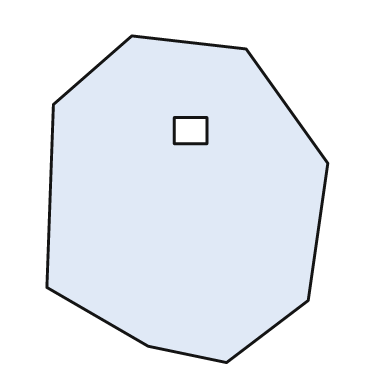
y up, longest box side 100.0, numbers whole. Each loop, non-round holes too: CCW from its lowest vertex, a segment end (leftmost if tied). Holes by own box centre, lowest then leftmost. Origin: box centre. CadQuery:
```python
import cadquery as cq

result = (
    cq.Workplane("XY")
    .moveTo(12.0, -50.0)
    .lineTo(37.0, -31.0)
    .lineTo(43.0, 11.0)
    .lineTo(18.0, 46.0)
    .lineTo(-17.0, 50.0)
    .lineTo(-41.0, 29.0)
    .lineTo(-43.0, -27.0)
    .lineTo(-12.0, -45.0)
    .close()
    .moveTo(-4.0, 17.0)
    .lineTo(6.0, 17.0)
    .lineTo(6.0, 25.0)
    .lineTo(-4.0, 25.0)
    .close()
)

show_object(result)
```